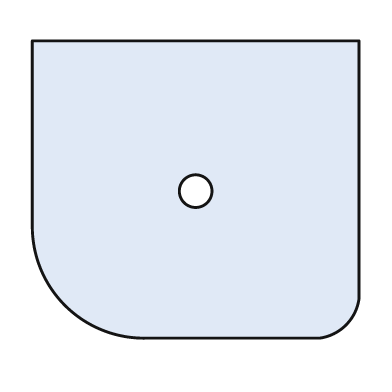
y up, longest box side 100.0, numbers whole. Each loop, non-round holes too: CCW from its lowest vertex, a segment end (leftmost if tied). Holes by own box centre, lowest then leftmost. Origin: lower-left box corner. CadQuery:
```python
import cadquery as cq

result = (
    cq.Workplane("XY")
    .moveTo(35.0, 0.0)
    .lineTo(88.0, 0.0)
    .threePointArc((96.0, 4.0), (100.0, 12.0))
    .lineTo(100.0, 91.0)
    .lineTo(0.0, 91.0)
    .lineTo(0.0, 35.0)
    .threePointArc((10.0, 10.0), (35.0, 0.0))
    .close()
    .moveTo(50.0, 45.0)
    .circle(5.0)
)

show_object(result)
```